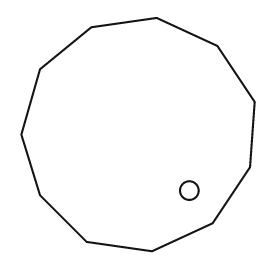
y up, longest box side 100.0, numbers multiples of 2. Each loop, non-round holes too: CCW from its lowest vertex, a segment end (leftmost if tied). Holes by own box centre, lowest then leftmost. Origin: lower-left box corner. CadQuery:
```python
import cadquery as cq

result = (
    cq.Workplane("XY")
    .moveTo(56.0, 0.0)
    .lineTo(82.0, 12.0)
    .lineTo(98.0, 36.0)
    .lineTo(100.0, 64.0)
    .lineTo(84.0, 88.0)
    .lineTo(58.0, 100.0)
    .lineTo(30.0, 96.0)
    .lineTo(8.0, 78.0)
    .lineTo(0.0, 50.0)
    .lineTo(8.0, 24.0)
    .lineTo(28.0, 4.0)
    .close()
    .moveTo(72.0, 26.0)
    .circle(4.0)
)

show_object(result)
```